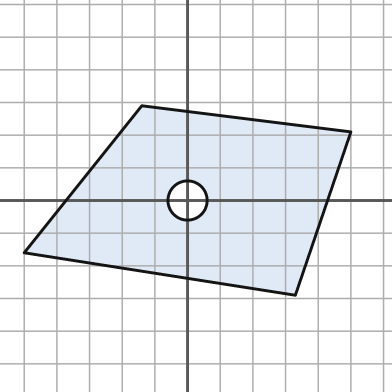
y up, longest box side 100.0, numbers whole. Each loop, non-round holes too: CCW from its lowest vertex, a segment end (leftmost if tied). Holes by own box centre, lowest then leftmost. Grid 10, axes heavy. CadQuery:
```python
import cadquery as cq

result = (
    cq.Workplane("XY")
    .moveTo(33.0, -29.0)
    .lineTo(50.0, 21.0)
    .lineTo(-14.0, 29.0)
    .lineTo(-50.0, -16.0)
    .close()
    .moveTo(0.0, 0.0)
    .circle(6.0)
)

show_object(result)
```